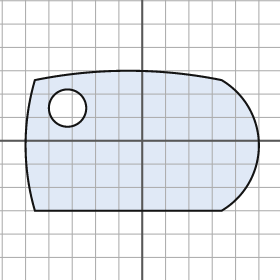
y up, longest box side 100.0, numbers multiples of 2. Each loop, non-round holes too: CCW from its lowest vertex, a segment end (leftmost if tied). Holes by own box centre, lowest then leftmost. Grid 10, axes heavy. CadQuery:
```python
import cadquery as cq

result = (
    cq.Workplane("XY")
    .moveTo(-46.0, -30.0)
    .lineTo(34.0, -30.0)
    .threePointArc((50.0, -2.0), (34.0, 26.0))
    .threePointArc((-6.0, 30.0), (-46.0, 26.0))
    .threePointArc((-50.0, -2.0), (-46.0, -30.0))
    .close()
    .moveTo(-32.0, 14.0)
    .circle(8.0)
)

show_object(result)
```